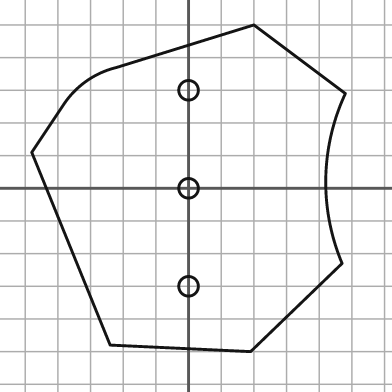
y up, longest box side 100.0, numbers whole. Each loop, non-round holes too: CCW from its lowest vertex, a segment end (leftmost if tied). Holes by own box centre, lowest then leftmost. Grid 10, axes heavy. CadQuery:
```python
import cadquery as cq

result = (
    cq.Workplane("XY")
    .moveTo(19.0, -50.0)
    .lineTo(47.0, -23.0)
    .threePointArc((42.0, 3.0), (48.0, 29.0))
    .lineTo(20.0, 50.0)
    .lineTo(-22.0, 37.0)
    .threePointArc((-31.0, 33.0), (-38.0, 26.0))
    .lineTo(-48.0, 11.0)
    .lineTo(-24.0, -48.0)
    .close()
    .moveTo(0.0, -30.0)
    .circle(3.0)
    .moveTo(0.0, 0.0)
    .circle(3.0)
    .moveTo(0.0, 30.0)
    .circle(3.0)
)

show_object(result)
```